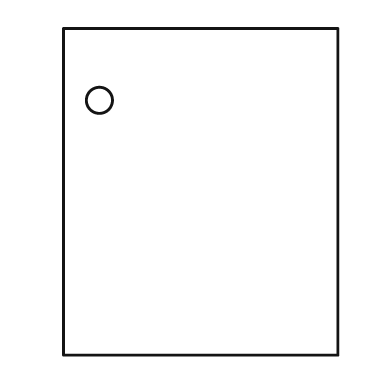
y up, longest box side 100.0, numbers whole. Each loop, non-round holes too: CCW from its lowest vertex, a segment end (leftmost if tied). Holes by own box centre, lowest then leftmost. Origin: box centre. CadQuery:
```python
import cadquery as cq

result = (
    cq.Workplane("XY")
    .moveTo(-42.0, -50.0)
    .lineTo(42.0, -50.0)
    .lineTo(42.0, 50.0)
    .lineTo(-42.0, 50.0)
    .close()
    .moveTo(-31.0, 28.0)
    .circle(4.0)
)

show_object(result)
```